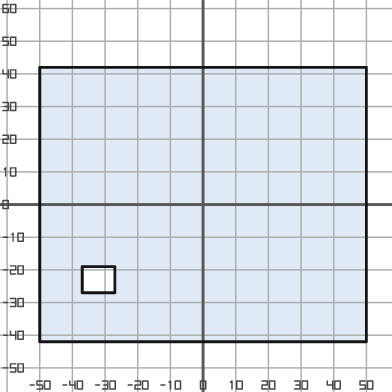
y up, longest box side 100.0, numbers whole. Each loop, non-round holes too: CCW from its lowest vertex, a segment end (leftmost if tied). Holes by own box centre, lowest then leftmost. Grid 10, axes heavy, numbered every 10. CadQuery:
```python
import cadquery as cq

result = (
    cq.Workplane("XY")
    .moveTo(-50.0, -42.0)
    .lineTo(50.0, -42.0)
    .lineTo(50.0, 42.0)
    .lineTo(-50.0, 42.0)
    .close()
    .moveTo(-37.0, -27.0)
    .lineTo(-27.0, -27.0)
    .lineTo(-27.0, -19.0)
    .lineTo(-37.0, -19.0)
    .close()
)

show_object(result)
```